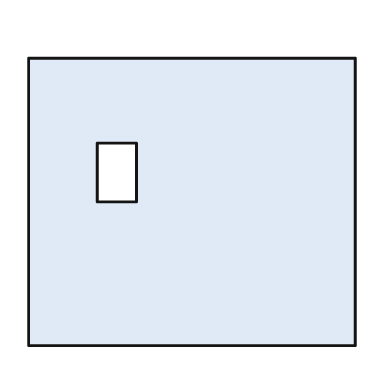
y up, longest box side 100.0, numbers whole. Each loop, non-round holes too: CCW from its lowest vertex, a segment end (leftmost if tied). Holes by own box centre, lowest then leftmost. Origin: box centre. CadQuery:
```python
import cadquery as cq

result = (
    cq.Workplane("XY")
    .moveTo(-50.0, -44.0)
    .lineTo(50.0, -44.0)
    .lineTo(50.0, 44.0)
    .lineTo(-50.0, 44.0)
    .close()
    .moveTo(-29.0, 0.0)
    .lineTo(-17.0, 0.0)
    .lineTo(-17.0, 18.0)
    .lineTo(-29.0, 18.0)
    .close()
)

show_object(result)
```